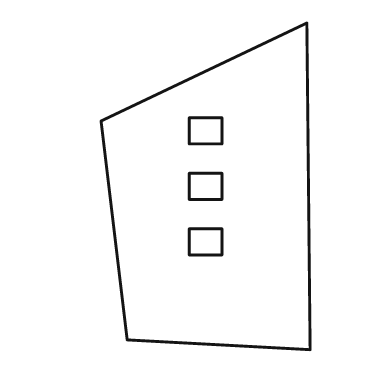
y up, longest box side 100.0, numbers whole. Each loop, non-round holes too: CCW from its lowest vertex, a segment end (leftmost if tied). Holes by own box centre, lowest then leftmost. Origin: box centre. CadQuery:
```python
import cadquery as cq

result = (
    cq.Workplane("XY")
    .moveTo(32.0, -50.0)
    .lineTo(31.0, 50.0)
    .lineTo(-32.0, 20.0)
    .lineTo(-24.0, -47.0)
    .close()
    .moveTo(-5.0, -21.0)
    .lineTo(5.0, -21.0)
    .lineTo(5.0, -13.0)
    .lineTo(-5.0, -13.0)
    .close()
    .moveTo(-5.0, -4.0)
    .lineTo(5.0, -4.0)
    .lineTo(5.0, 4.0)
    .lineTo(-5.0, 4.0)
    .close()
    .moveTo(-5.0, 13.0)
    .lineTo(5.0, 13.0)
    .lineTo(5.0, 21.0)
    .lineTo(-5.0, 21.0)
    .close()
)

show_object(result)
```